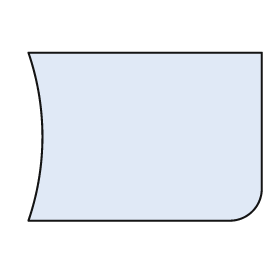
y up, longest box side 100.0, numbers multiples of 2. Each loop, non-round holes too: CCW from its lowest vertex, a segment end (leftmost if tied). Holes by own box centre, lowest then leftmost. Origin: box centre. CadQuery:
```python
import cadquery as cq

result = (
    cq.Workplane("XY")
    .moveTo(-50.0, -36.0)
    .lineTo(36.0, -36.0)
    .threePointArc((46.0, -32.0), (50.0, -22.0))
    .lineTo(50.0, 36.0)
    .lineTo(-50.0, 36.0)
    .threePointArc((-44.0, 0.0), (-50.0, -36.0))
    .close()
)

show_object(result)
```